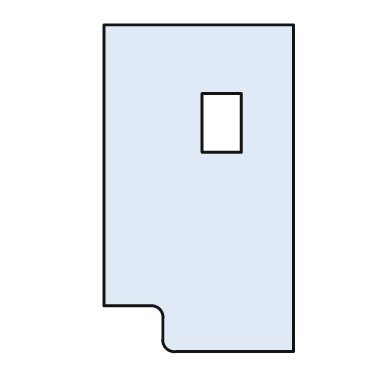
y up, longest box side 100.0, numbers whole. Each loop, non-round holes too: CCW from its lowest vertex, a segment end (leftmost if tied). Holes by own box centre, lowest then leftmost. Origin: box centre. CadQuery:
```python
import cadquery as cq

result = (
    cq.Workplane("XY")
    .moveTo(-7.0, -50.0)
    .lineTo(29.0, -50.0)
    .lineTo(29.0, 50.0)
    .lineTo(-29.0, 50.0)
    .lineTo(-29.0, -36.0)
    .lineTo(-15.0, -36.0)
    .threePointArc((-12.0, -37.0), (-11.0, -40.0))
    .lineTo(-11.0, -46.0)
    .threePointArc((-10.0, -49.0), (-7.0, -50.0))
    .close()
    .moveTo(1.0, 11.0)
    .lineTo(13.0, 11.0)
    .lineTo(13.0, 29.0)
    .lineTo(1.0, 29.0)
    .close()
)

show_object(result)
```